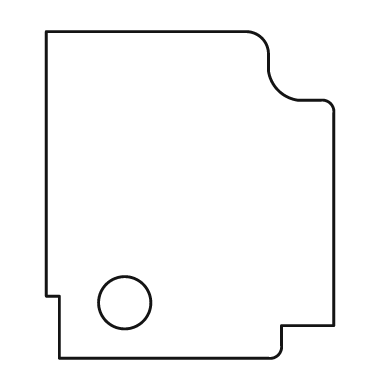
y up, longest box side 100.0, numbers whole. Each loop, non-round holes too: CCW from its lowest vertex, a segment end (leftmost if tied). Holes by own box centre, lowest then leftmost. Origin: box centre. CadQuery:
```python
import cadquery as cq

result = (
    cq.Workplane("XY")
    .moveTo(-40.0, -50.0)
    .lineTo(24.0, -50.0)
    .threePointArc((27.0, -49.0), (28.0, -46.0))
    .lineTo(28.0, -40.0)
    .lineTo(44.0, -40.0)
    .lineTo(44.0, 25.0)
    .threePointArc((43.0, 28.0), (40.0, 29.0))
    .lineTo(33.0, 29.0)
    .threePointArc((27.0, 32.0), (24.0, 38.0))
    .lineTo(24.0, 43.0)
    .threePointArc((22.0, 48.0), (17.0, 50.0))
    .lineTo(-44.0, 50.0)
    .lineTo(-44.0, -31.0)
    .lineTo(-40.0, -31.0)
    .close()
    .moveTo(-20.0, -33.0)
    .circle(8.0)
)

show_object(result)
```